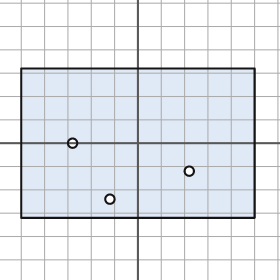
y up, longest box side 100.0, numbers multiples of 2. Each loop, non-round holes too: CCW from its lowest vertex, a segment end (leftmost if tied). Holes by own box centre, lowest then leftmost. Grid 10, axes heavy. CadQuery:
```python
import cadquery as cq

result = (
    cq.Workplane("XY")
    .moveTo(-50.0, -32.0)
    .lineTo(50.0, -32.0)
    .lineTo(50.0, 32.0)
    .lineTo(-50.0, 32.0)
    .close()
    .moveTo(-12.0, -24.0)
    .circle(2.0)
    .moveTo(22.0, -12.0)
    .circle(2.0)
    .moveTo(-28.0, 0.0)
    .circle(2.0)
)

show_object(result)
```